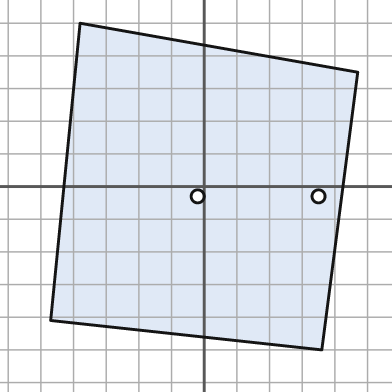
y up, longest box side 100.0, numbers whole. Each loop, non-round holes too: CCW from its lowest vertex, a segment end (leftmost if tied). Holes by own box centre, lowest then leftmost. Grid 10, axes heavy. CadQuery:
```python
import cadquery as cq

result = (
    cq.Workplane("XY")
    .moveTo(36.0, -50.0)
    .lineTo(47.0, 35.0)
    .lineTo(-38.0, 50.0)
    .lineTo(-47.0, -41.0)
    .close()
    .moveTo(-2.0, -3.0)
    .circle(2.0)
    .moveTo(35.0, -3.0)
    .circle(2.0)
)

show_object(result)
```